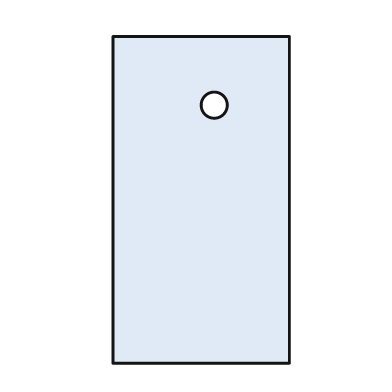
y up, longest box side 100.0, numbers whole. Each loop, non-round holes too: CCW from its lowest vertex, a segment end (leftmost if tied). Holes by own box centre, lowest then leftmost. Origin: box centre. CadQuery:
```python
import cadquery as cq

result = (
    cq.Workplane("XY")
    .moveTo(-27.0, -50.0)
    .lineTo(27.0, -50.0)
    .lineTo(27.0, 50.0)
    .lineTo(-27.0, 50.0)
    .close()
    .moveTo(4.0, 29.0)
    .circle(4.0)
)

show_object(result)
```